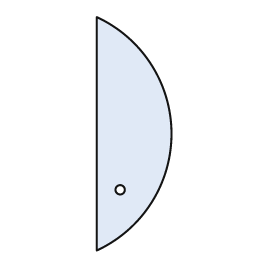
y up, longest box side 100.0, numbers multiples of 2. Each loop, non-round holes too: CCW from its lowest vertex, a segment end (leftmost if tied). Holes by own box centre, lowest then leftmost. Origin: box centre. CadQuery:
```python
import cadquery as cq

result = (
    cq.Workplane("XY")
    .moveTo(-16.0, -50.0)
    .threePointArc((16.0, 0.0), (-16.0, 50.0))
    .close()
    .moveTo(-6.0, -24.0)
    .circle(2.0)
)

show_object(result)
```